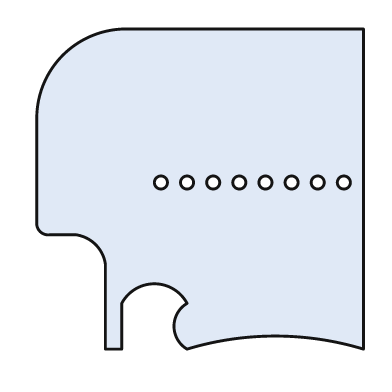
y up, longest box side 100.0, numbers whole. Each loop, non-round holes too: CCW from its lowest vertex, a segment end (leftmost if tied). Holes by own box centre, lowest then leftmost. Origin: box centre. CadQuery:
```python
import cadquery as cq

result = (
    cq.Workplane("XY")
    .moveTo(-29.0, -49.0)
    .lineTo(-24.0, -49.0)
    .lineTo(-24.0, -35.0)
    .threePointArc((-14.0, -29.0), (-4.0, -35.0))
    .threePointArc((-8.0, -42.0), (-4.0, -49.0))
    .threePointArc((23.0, -45.0), (50.0, -49.0))
    .lineTo(50.0, 49.0)
    .lineTo(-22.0, 49.0)
    .threePointArc((-42.0, 41.0), (-50.0, 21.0))
    .lineTo(-50.0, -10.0)
    .threePointArc((-49.0, -13.0), (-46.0, -14.0))
    .lineTo(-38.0, -14.0)
    .threePointArc((-32.0, -17.0), (-29.0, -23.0))
    .close()
    .moveTo(-12.0, 2.0)
    .circle(2.0)
    .moveTo(-4.0, 2.0)
    .circle(2.0)
    .moveTo(4.0, 2.0)
    .circle(2.0)
    .moveTo(12.0, 2.0)
    .circle(2.0)
    .moveTo(20.0, 2.0)
    .circle(2.0)
    .moveTo(28.0, 2.0)
    .circle(2.0)
    .moveTo(36.0, 2.0)
    .circle(2.0)
    .moveTo(44.0, 2.0)
    .circle(2.0)
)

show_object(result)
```